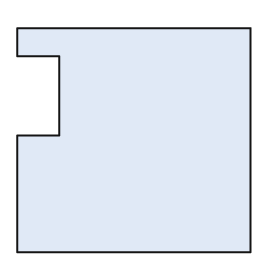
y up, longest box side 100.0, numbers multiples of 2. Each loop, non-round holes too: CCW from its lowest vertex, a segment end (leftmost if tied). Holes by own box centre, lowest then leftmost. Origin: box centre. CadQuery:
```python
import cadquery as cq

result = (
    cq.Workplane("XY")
    .moveTo(-50.0, -48.0)
    .lineTo(50.0, -48.0)
    .lineTo(50.0, 48.0)
    .lineTo(-50.0, 48.0)
    .lineTo(-50.0, 36.0)
    .lineTo(-32.0, 36.0)
    .lineTo(-32.0, 2.0)
    .lineTo(-50.0, 2.0)
    .close()
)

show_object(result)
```